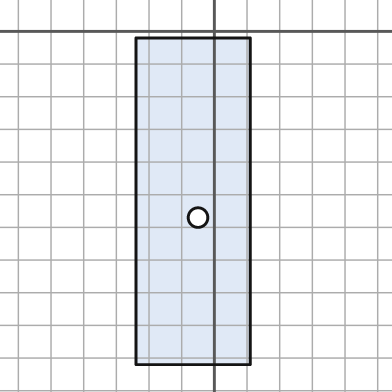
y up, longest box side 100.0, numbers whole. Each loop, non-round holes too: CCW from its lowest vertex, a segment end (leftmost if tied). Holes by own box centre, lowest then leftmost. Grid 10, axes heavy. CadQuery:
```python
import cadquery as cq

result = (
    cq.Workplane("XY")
    .moveTo(-24.0, -102.0)
    .lineTo(11.0, -102.0)
    .lineTo(11.0, -2.0)
    .lineTo(-24.0, -2.0)
    .close()
    .moveTo(-5.0, -57.0)
    .circle(3.0)
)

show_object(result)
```